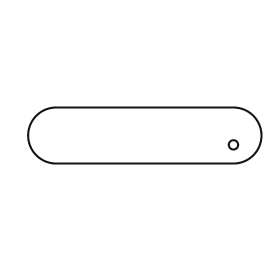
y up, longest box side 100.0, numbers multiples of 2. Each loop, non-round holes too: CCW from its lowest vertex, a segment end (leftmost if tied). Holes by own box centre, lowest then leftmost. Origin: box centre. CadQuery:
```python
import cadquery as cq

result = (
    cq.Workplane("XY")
    .moveTo(-38.0, -12.0)
    .lineTo(38.0, -12.0)
    .threePointArc((50.0, 0.0), (38.0, 12.0))
    .lineTo(-38.0, 12.0)
    .threePointArc((-50.0, 0.0), (-38.0, -12.0))
    .close()
    .moveTo(38.0, -4.0)
    .circle(2.0)
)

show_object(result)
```